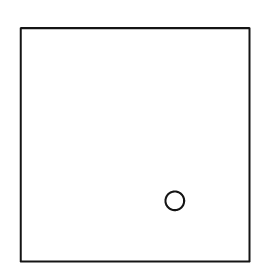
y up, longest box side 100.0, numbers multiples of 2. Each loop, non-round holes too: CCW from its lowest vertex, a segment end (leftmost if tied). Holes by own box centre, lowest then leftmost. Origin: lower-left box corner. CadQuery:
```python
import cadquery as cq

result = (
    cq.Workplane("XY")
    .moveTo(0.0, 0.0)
    .lineTo(98.0, 0.0)
    .lineTo(98.0, 100.0)
    .lineTo(0.0, 100.0)
    .close()
    .moveTo(66.0, 26.0)
    .circle(4.0)
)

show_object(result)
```